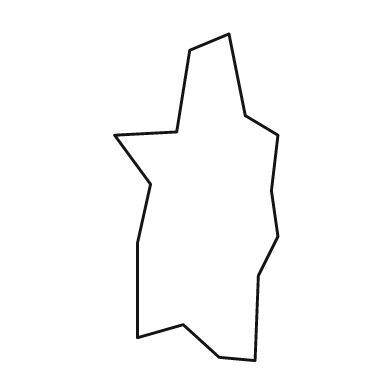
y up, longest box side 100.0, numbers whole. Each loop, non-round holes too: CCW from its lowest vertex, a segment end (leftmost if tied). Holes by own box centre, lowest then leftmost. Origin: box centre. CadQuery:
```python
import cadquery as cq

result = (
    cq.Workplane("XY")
    .moveTo(18.0, -50.0)
    .lineTo(19.0, -24.0)
    .lineTo(25.0, -12.0)
    .lineTo(23.0, 2.0)
    .lineTo(25.0, 19.0)
    .lineTo(15.0, 25.0)
    .lineTo(10.0, 50.0)
    .lineTo(-2.0, 45.0)
    .lineTo(-6.0, 20.0)
    .lineTo(-25.0, 19.0)
    .lineTo(-14.0, 4.0)
    .lineTo(-18.0, -14.0)
    .lineTo(-18.0, -43.0)
    .lineTo(-4.0, -39.0)
    .lineTo(7.0, -49.0)
    .close()
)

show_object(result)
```